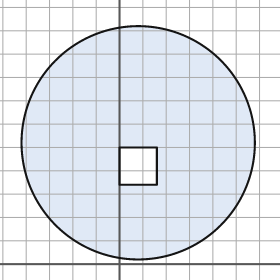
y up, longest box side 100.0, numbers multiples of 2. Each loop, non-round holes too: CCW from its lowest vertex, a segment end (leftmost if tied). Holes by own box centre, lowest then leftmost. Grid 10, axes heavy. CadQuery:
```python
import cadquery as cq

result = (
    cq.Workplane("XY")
    .moveTo(8.0, 52.0)
    .circle(50.0)
    .moveTo(0.0, 34.0)
    .lineTo(16.0, 34.0)
    .lineTo(16.0, 50.0)
    .lineTo(0.0, 50.0)
    .close()
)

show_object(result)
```